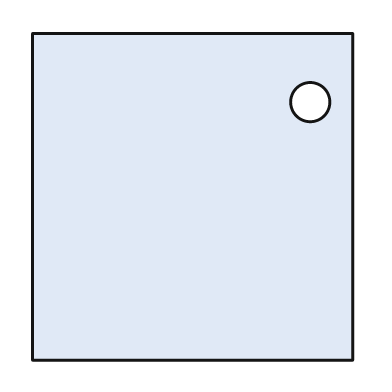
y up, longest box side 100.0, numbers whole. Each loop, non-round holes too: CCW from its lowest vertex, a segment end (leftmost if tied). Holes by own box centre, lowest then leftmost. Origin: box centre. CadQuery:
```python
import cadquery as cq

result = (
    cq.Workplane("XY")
    .moveTo(-49.0, -50.0)
    .lineTo(49.0, -50.0)
    .lineTo(49.0, 50.0)
    .lineTo(-49.0, 50.0)
    .close()
    .moveTo(36.0, 29.0)
    .circle(6.0)
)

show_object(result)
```